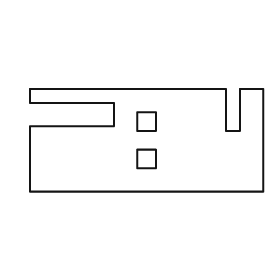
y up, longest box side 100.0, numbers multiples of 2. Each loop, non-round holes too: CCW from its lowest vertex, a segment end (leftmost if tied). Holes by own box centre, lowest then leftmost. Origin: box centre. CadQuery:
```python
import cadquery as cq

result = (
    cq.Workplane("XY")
    .moveTo(-50.0, -22.0)
    .lineTo(50.0, -22.0)
    .lineTo(50.0, 22.0)
    .lineTo(40.0, 22.0)
    .lineTo(40.0, 4.0)
    .lineTo(34.0, 4.0)
    .lineTo(34.0, 22.0)
    .lineTo(-50.0, 22.0)
    .lineTo(-50.0, 16.0)
    .lineTo(-14.0, 16.0)
    .lineTo(-14.0, 6.0)
    .lineTo(-50.0, 6.0)
    .close()
    .moveTo(-4.0, -12.0)
    .lineTo(4.0, -12.0)
    .lineTo(4.0, -4.0)
    .lineTo(-4.0, -4.0)
    .close()
    .moveTo(-4.0, 4.0)
    .lineTo(4.0, 4.0)
    .lineTo(4.0, 12.0)
    .lineTo(-4.0, 12.0)
    .close()
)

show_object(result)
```